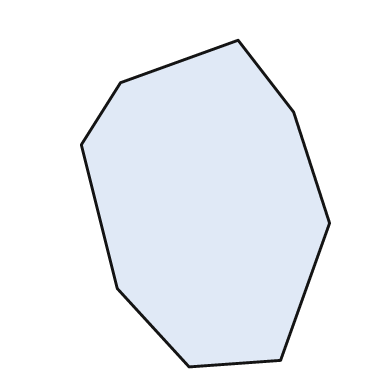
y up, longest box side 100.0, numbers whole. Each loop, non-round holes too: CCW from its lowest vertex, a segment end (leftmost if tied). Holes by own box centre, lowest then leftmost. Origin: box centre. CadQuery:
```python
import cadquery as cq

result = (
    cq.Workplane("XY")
    .moveTo(-5.0, -50.0)
    .lineTo(23.0, -48.0)
    .lineTo(38.0, -6.0)
    .lineTo(27.0, 28.0)
    .lineTo(10.0, 50.0)
    .lineTo(-26.0, 37.0)
    .lineTo(-38.0, 18.0)
    .lineTo(-27.0, -26.0)
    .close()
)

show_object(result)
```